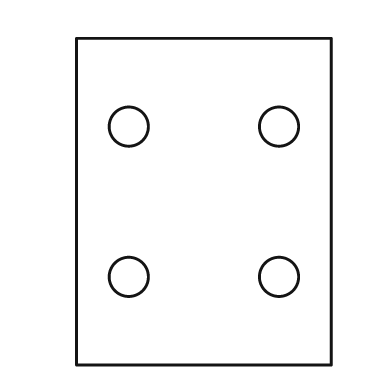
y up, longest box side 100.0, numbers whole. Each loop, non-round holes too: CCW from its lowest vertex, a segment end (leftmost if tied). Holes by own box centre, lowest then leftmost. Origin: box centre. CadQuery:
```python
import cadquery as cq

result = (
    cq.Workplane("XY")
    .moveTo(-39.0, -50.0)
    .lineTo(39.0, -50.0)
    .lineTo(39.0, 50.0)
    .lineTo(-39.0, 50.0)
    .close()
    .moveTo(-23.0, -23.0)
    .circle(6.0)
    .moveTo(23.0, -23.0)
    .circle(6.0)
    .moveTo(-23.0, 23.0)
    .circle(6.0)
    .moveTo(23.0, 23.0)
    .circle(6.0)
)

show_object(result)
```